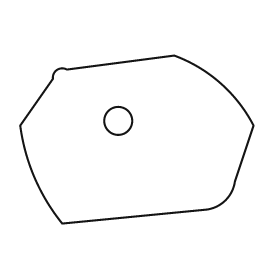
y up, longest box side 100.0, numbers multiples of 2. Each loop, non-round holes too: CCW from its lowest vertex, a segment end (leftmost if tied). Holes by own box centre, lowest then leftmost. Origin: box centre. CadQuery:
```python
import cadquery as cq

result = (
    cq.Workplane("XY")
    .moveTo(-32.0, -36.0)
    .lineTo(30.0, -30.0)
    .threePointArc((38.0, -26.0), (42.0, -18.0))
    .lineTo(50.0, 6.0)
    .threePointArc((36.0, 24.0), (16.0, 36.0))
    .lineTo(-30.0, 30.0)
    .threePointArc((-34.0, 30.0), (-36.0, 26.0))
    .lineTo(-50.0, 6.0)
    .threePointArc((-44.0, -16.0), (-32.0, -36.0))
    .close()
    .moveTo(-8.0, 8.0)
    .circle(6.0)
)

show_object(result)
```